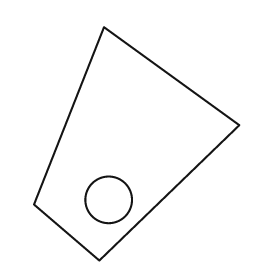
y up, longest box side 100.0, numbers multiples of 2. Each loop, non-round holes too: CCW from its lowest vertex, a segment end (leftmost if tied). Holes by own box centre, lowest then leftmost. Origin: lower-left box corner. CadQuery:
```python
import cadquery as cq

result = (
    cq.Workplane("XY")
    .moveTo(28.0, 0.0)
    .lineTo(88.0, 58.0)
    .lineTo(30.0, 100.0)
    .lineTo(0.0, 24.0)
    .close()
    .moveTo(32.0, 26.0)
    .circle(10.0)
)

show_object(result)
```